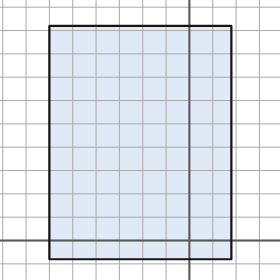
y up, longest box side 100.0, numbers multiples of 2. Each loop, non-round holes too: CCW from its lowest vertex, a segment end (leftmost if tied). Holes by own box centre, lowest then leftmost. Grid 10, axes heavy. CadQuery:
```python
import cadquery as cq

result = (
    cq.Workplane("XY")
    .moveTo(-60.0, -8.0)
    .lineTo(18.0, -8.0)
    .lineTo(18.0, 92.0)
    .lineTo(-60.0, 92.0)
    .close()
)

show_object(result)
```